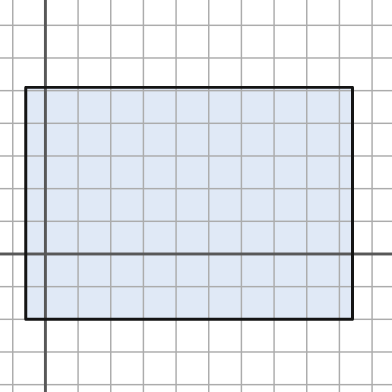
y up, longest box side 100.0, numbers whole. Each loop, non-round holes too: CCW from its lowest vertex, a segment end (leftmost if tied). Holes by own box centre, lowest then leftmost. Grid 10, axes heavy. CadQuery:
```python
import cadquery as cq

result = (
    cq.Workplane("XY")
    .moveTo(-6.0, -20.0)
    .lineTo(94.0, -20.0)
    .lineTo(94.0, 51.0)
    .lineTo(-6.0, 51.0)
    .close()
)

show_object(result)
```